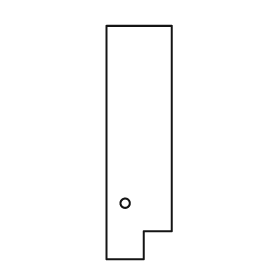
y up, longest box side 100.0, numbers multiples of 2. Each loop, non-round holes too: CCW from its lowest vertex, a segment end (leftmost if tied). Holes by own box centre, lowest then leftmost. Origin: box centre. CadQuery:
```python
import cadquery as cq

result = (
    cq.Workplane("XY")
    .moveTo(-14.0, -50.0)
    .lineTo(2.0, -50.0)
    .lineTo(2.0, -38.0)
    .lineTo(14.0, -38.0)
    .lineTo(14.0, 50.0)
    .lineTo(-14.0, 50.0)
    .close()
    .moveTo(-6.0, -26.0)
    .circle(2.0)
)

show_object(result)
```